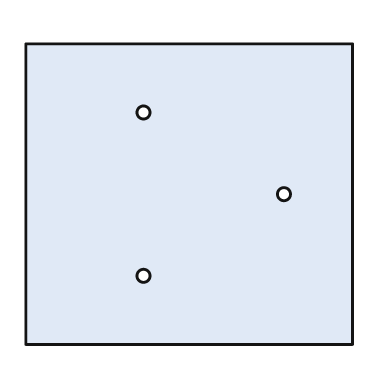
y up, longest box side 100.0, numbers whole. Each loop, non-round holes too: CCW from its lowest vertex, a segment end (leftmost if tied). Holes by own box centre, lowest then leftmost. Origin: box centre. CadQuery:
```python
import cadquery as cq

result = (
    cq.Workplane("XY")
    .moveTo(-50.0, -46.0)
    .lineTo(50.0, -46.0)
    .lineTo(50.0, 46.0)
    .lineTo(-50.0, 46.0)
    .close()
    .moveTo(-14.0, -25.0)
    .circle(2.0)
    .moveTo(29.0, 0.0)
    .circle(2.0)
    .moveTo(-14.0, 25.0)
    .circle(2.0)
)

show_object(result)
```